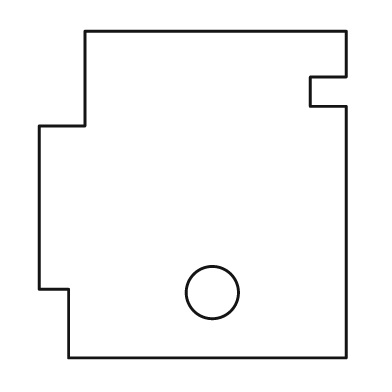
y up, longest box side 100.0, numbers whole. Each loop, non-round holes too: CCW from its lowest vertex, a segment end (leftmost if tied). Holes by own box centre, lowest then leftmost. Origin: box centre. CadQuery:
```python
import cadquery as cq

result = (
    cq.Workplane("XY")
    .moveTo(-38.0, -50.0)
    .lineTo(47.0, -50.0)
    .lineTo(47.0, 27.0)
    .lineTo(36.0, 27.0)
    .lineTo(36.0, 36.0)
    .lineTo(47.0, 36.0)
    .lineTo(47.0, 50.0)
    .lineTo(-33.0, 50.0)
    .lineTo(-33.0, 21.0)
    .lineTo(-47.0, 21.0)
    .lineTo(-47.0, -29.0)
    .lineTo(-38.0, -29.0)
    .close()
    .moveTo(6.0, -30.0)
    .circle(8.0)
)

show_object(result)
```